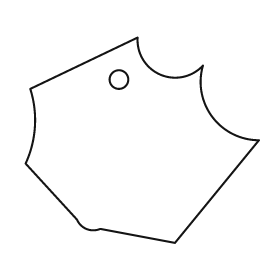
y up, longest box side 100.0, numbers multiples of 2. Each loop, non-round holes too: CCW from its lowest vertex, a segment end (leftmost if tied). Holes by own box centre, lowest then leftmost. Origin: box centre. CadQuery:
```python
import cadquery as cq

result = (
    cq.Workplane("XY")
    .moveTo(14.0, -44.0)
    .lineTo(50.0, 0.0)
    .threePointArc((30.0, 10.0), (26.0, 32.0))
    .threePointArc((8.0, 28.0), (-2.0, 44.0))
    .lineTo(-48.0, 22.0)
    .threePointArc((-46.0, 6.0), (-50.0, -10.0))
    .lineTo(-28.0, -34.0)
    .threePointArc((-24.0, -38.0), (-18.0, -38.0))
    .close()
    .moveTo(-10.0, 26.0)
    .circle(4.0)
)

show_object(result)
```